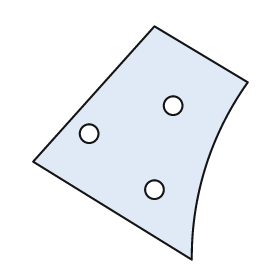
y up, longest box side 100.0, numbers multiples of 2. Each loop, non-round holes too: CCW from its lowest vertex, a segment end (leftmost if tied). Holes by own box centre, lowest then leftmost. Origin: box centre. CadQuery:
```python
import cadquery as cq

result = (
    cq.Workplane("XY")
    .moveTo(22.0, -50.0)
    .threePointArc((28.0, -10.0), (46.0, 26.0))
    .lineTo(6.0, 50.0)
    .lineTo(-46.0, -8.0)
    .close()
    .moveTo(6.0, -20.0)
    .circle(4.0)
    .moveTo(-22.0, 4.0)
    .circle(4.0)
    .moveTo(14.0, 16.0)
    .circle(4.0)
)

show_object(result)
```